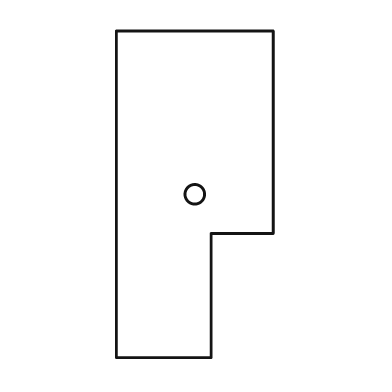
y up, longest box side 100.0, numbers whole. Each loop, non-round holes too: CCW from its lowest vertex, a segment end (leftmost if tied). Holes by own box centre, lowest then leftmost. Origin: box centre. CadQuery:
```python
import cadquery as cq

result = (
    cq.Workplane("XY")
    .moveTo(-24.0, -50.0)
    .lineTo(5.0, -50.0)
    .lineTo(5.0, -12.0)
    .lineTo(24.0, -12.0)
    .lineTo(24.0, 50.0)
    .lineTo(-24.0, 50.0)
    .close()
    .moveTo(0.0, 0.0)
    .circle(3.0)
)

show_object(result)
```